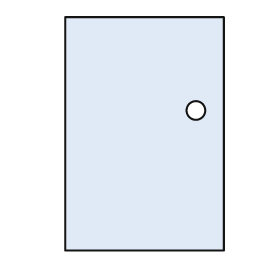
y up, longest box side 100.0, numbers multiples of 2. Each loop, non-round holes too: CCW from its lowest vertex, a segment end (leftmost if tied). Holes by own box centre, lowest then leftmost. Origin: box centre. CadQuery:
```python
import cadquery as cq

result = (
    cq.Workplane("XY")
    .moveTo(-34.0, -50.0)
    .lineTo(34.0, -50.0)
    .lineTo(34.0, 50.0)
    .lineTo(-34.0, 50.0)
    .close()
    .moveTo(22.0, 10.0)
    .circle(4.0)
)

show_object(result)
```